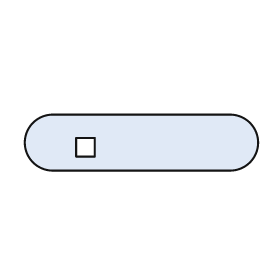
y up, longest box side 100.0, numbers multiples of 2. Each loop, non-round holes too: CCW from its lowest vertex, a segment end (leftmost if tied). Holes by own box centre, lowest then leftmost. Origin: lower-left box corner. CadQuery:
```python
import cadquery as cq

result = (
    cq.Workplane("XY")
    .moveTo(12.0, 0.0)
    .lineTo(88.0, 0.0)
    .threePointArc((100.0, 12.0), (88.0, 24.0))
    .lineTo(12.0, 24.0)
    .threePointArc((0.0, 12.0), (12.0, 0.0))
    .close()
    .moveTo(22.0, 6.0)
    .lineTo(30.0, 6.0)
    .lineTo(30.0, 14.0)
    .lineTo(22.0, 14.0)
    .close()
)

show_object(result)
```